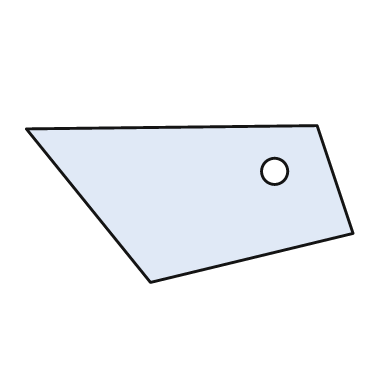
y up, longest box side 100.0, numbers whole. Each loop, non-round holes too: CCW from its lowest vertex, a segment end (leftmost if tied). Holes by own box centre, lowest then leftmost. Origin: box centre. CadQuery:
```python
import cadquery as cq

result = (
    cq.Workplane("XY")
    .moveTo(-12.0, -24.0)
    .lineTo(50.0, -9.0)
    .lineTo(39.0, 24.0)
    .lineTo(-50.0, 23.0)
    .close()
    .moveTo(26.0, 10.0)
    .circle(4.0)
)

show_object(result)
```